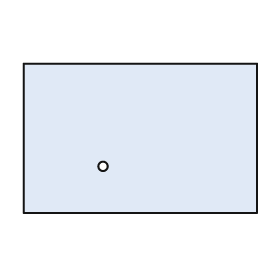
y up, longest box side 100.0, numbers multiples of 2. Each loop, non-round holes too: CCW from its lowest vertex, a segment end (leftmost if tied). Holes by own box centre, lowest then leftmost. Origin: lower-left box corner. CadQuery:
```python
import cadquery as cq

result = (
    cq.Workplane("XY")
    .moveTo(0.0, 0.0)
    .lineTo(100.0, 0.0)
    .lineTo(100.0, 64.0)
    .lineTo(0.0, 64.0)
    .close()
    .moveTo(34.0, 20.0)
    .circle(2.0)
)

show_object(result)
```